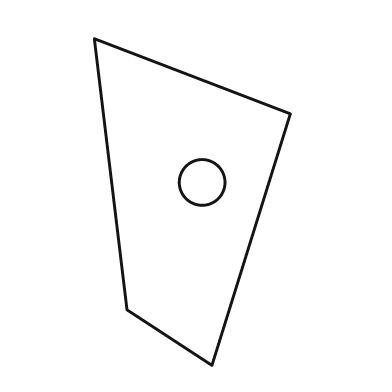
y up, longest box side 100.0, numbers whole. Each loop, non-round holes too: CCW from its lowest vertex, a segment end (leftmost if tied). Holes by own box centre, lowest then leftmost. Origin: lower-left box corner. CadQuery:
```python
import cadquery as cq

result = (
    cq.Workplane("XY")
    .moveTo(36.0, 0.0)
    .lineTo(60.0, 77.0)
    .lineTo(0.0, 100.0)
    .lineTo(10.0, 17.0)
    .close()
    .moveTo(33.0, 56.0)
    .circle(7.0)
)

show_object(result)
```